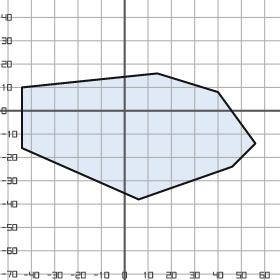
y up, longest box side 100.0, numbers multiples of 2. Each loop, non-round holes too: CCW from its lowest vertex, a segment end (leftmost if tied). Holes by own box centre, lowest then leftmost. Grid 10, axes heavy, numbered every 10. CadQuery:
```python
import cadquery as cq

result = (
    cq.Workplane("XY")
    .moveTo(6.0, -38.0)
    .lineTo(46.0, -24.0)
    .lineTo(56.0, -14.0)
    .lineTo(40.0, 8.0)
    .lineTo(14.0, 16.0)
    .lineTo(-44.0, 10.0)
    .lineTo(-44.0, -16.0)
    .close()
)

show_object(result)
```